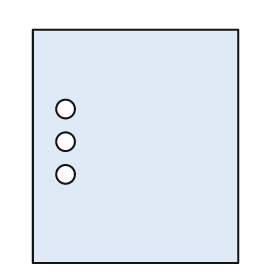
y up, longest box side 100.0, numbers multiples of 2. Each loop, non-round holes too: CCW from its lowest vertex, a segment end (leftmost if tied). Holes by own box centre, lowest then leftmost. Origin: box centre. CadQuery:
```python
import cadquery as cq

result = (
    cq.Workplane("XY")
    .moveTo(-44.0, -50.0)
    .lineTo(44.0, -50.0)
    .lineTo(44.0, 50.0)
    .lineTo(-44.0, 50.0)
    .close()
    .moveTo(-30.0, -12.0)
    .circle(4.0)
    .moveTo(-30.0, 2.0)
    .circle(4.0)
    .moveTo(-30.0, 16.0)
    .circle(4.0)
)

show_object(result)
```